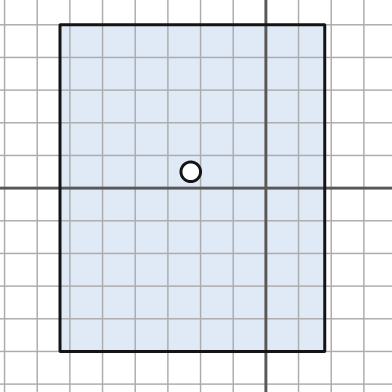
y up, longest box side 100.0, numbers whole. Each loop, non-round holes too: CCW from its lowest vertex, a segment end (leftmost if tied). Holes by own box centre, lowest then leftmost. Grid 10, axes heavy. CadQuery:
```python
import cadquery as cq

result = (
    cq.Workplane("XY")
    .moveTo(-63.0, -50.0)
    .lineTo(18.0, -50.0)
    .lineTo(18.0, 50.0)
    .lineTo(-63.0, 50.0)
    .close()
    .moveTo(-23.0, 5.0)
    .circle(3.0)
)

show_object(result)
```